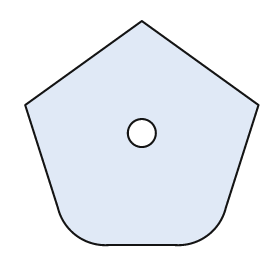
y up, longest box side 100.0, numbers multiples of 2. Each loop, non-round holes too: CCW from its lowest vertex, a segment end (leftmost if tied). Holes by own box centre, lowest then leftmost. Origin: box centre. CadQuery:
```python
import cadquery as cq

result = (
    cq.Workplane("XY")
    .moveTo(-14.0, -48.0)
    .lineTo(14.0, -48.0)
    .threePointArc((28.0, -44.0), (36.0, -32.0))
    .lineTo(50.0, 12.0)
    .lineTo(0.0, 48.0)
    .lineTo(-50.0, 12.0)
    .lineTo(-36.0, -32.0)
    .threePointArc((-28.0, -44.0), (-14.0, -48.0))
    .close()
    .moveTo(0.0, 0.0)
    .circle(6.0)
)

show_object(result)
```